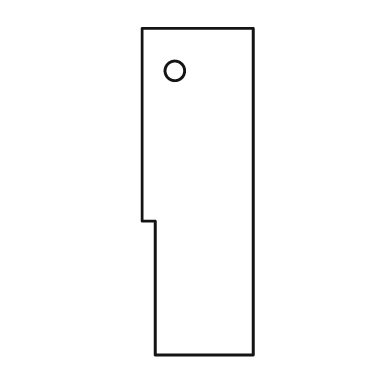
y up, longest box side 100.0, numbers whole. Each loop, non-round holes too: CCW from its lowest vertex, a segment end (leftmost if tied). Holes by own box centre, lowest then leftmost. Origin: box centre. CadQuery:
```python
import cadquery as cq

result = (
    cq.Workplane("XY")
    .moveTo(-13.0, -50.0)
    .lineTo(17.0, -50.0)
    .lineTo(17.0, 50.0)
    .lineTo(-17.0, 50.0)
    .lineTo(-17.0, -9.0)
    .lineTo(-13.0, -9.0)
    .close()
    .moveTo(-7.0, 37.0)
    .circle(3.0)
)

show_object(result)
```